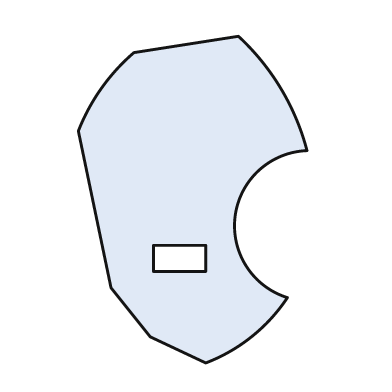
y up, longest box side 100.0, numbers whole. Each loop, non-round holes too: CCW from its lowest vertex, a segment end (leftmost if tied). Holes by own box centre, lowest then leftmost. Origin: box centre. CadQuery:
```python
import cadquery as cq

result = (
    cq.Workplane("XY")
    .moveTo(4.0, -50.0)
    .threePointArc((18.0, -42.0), (29.0, -30.0))
    .threePointArc((13.0, -5.0), (35.0, 15.0))
    .threePointArc((27.0, 34.0), (14.0, 50.0))
    .lineTo(-18.0, 45.0)
    .threePointArc((-28.0, 34.0), (-35.0, 21.0))
    .lineTo(-25.0, -27.0)
    .lineTo(-13.0, -42.0)
    .close()
    .moveTo(-12.0, -22.0)
    .lineTo(4.0, -22.0)
    .lineTo(4.0, -14.0)
    .lineTo(-12.0, -14.0)
    .close()
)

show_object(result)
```